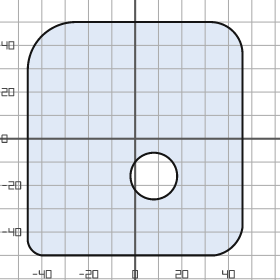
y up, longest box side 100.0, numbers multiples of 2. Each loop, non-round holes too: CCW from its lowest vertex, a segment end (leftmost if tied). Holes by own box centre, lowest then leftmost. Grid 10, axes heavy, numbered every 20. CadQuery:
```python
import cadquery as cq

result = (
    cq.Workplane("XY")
    .moveTo(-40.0, -50.0)
    .lineTo(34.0, -50.0)
    .threePointArc((42.0, -46.0), (46.0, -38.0))
    .lineTo(46.0, 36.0)
    .threePointArc((42.0, 46.0), (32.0, 50.0))
    .lineTo(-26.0, 50.0)
    .threePointArc((-40.0, 44.0), (-46.0, 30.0))
    .lineTo(-46.0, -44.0)
    .threePointArc((-44.0, -48.0), (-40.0, -50.0))
    .close()
    .moveTo(8.0, -16.0)
    .circle(10.0)
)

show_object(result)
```